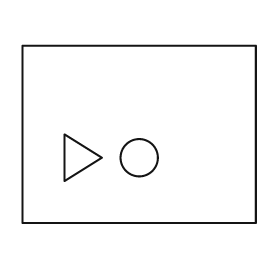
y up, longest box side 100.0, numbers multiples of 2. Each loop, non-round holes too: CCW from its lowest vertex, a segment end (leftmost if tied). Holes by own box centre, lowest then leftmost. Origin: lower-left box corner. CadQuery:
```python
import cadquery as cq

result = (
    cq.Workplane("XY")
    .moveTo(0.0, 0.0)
    .lineTo(100.0, 0.0)
    .lineTo(100.0, 76.0)
    .lineTo(0.0, 76.0)
    .close()
    .moveTo(18.0, 18.0)
    .lineTo(34.0, 28.0)
    .lineTo(18.0, 38.0)
    .close()
    .moveTo(50.0, 28.0)
    .circle(8.0)
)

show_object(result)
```